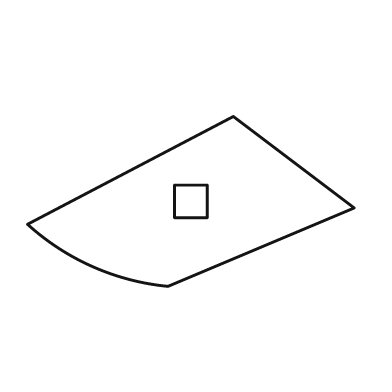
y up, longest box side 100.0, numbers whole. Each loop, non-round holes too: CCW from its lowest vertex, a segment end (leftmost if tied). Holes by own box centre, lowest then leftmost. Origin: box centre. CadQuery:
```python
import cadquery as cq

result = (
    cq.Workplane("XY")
    .moveTo(-7.0, -26.0)
    .lineTo(50.0, -2.0)
    .lineTo(13.0, 26.0)
    .lineTo(-50.0, -7.0)
    .threePointArc((-30.0, -20.0), (-7.0, -26.0))
    .close()
    .moveTo(-5.0, -5.0)
    .lineTo(5.0, -5.0)
    .lineTo(5.0, 5.0)
    .lineTo(-5.0, 5.0)
    .close()
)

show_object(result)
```